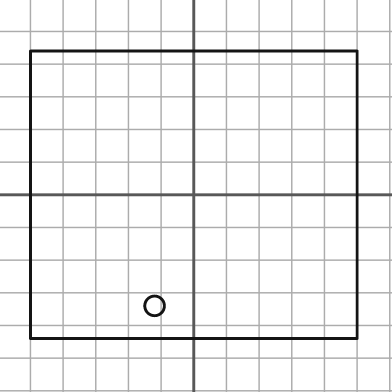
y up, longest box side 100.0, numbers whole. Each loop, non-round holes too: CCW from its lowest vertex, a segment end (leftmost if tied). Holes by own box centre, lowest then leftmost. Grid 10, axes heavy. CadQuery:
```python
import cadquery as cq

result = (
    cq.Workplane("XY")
    .moveTo(-50.0, -44.0)
    .lineTo(50.0, -44.0)
    .lineTo(50.0, 44.0)
    .lineTo(-50.0, 44.0)
    .close()
    .moveTo(-12.0, -34.0)
    .circle(3.0)
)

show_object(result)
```